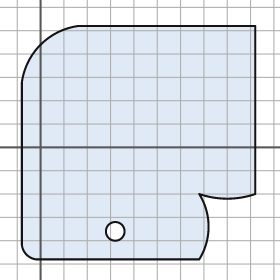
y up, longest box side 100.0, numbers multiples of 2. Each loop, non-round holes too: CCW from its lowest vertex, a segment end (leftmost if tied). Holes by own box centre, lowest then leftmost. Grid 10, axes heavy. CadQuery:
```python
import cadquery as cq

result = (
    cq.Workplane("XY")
    .moveTo(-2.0, -48.0)
    .lineTo(68.0, -48.0)
    .threePointArc((72.0, -34.0), (68.0, -20.0))
    .threePointArc((80.0, -22.0), (92.0, -20.0))
    .lineTo(92.0, 52.0)
    .lineTo(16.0, 52.0)
    .threePointArc((0.0, 44.0), (-8.0, 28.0))
    .lineTo(-8.0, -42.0)
    .threePointArc((-6.0, -46.0), (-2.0, -48.0))
    .close()
    .moveTo(32.0, -36.0)
    .circle(4.0)
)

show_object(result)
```